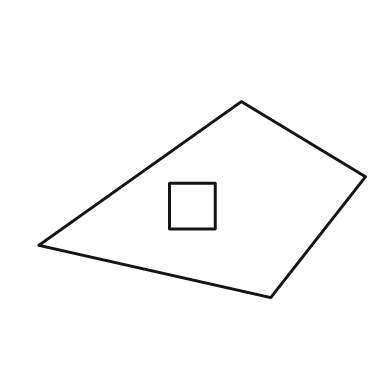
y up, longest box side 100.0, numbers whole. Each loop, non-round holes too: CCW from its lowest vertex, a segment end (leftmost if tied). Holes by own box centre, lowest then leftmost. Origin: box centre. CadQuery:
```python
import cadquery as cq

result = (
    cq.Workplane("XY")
    .moveTo(21.0, -30.0)
    .lineTo(50.0, 7.0)
    .lineTo(12.0, 30.0)
    .lineTo(-50.0, -14.0)
    .close()
    .moveTo(-10.0, -9.0)
    .lineTo(4.0, -9.0)
    .lineTo(4.0, 5.0)
    .lineTo(-10.0, 5.0)
    .close()
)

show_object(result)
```